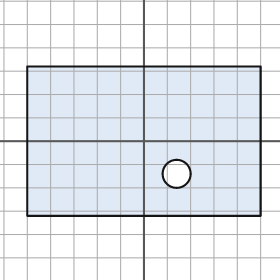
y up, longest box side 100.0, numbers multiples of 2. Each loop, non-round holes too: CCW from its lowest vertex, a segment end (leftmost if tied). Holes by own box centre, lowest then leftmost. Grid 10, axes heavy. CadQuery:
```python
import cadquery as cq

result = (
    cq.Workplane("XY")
    .moveTo(-50.0, -32.0)
    .lineTo(50.0, -32.0)
    .lineTo(50.0, 32.0)
    .lineTo(-50.0, 32.0)
    .close()
    .moveTo(14.0, -14.0)
    .circle(6.0)
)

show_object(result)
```